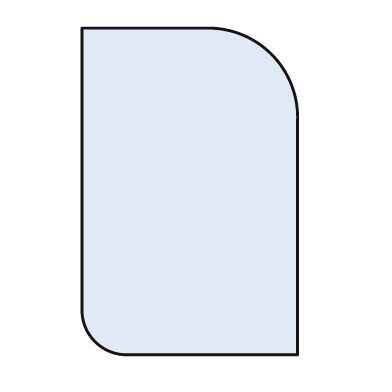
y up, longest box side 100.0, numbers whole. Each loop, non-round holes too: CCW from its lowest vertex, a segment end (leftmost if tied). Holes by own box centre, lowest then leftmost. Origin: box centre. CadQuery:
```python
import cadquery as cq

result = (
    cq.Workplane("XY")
    .moveTo(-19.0, -50.0)
    .lineTo(33.0, -50.0)
    .lineTo(33.0, 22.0)
    .threePointArc((25.0, 42.0), (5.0, 50.0))
    .lineTo(-33.0, 50.0)
    .lineTo(-33.0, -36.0)
    .threePointArc((-29.0, -46.0), (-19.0, -50.0))
    .close()
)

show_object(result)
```